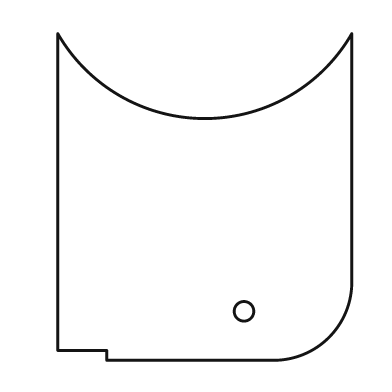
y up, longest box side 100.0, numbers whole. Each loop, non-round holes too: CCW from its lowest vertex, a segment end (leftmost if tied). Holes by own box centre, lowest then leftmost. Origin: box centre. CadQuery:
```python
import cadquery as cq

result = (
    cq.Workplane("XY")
    .moveTo(-30.0, -50.0)
    .lineTo(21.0, -50.0)
    .threePointArc((38.0, -43.0), (45.0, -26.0))
    .lineTo(45.0, 50.0)
    .threePointArc((0.0, 24.0), (-45.0, 50.0))
    .lineTo(-45.0, -47.0)
    .lineTo(-30.0, -47.0)
    .close()
    .moveTo(12.0, -35.0)
    .circle(3.0)
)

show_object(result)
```